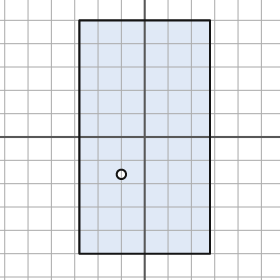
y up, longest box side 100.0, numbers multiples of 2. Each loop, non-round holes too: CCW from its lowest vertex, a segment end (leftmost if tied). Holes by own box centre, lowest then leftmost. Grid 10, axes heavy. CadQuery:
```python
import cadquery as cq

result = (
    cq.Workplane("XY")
    .moveTo(-28.0, -50.0)
    .lineTo(28.0, -50.0)
    .lineTo(28.0, 50.0)
    .lineTo(-28.0, 50.0)
    .close()
    .moveTo(-10.0, -16.0)
    .circle(2.0)
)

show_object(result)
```